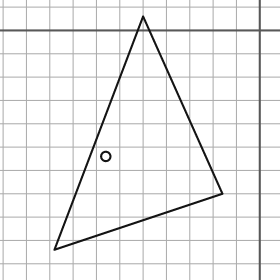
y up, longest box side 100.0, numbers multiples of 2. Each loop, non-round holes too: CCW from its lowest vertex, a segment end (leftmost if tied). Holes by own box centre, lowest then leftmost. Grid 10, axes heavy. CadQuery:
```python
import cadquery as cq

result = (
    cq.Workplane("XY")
    .moveTo(-88.0, -94.0)
    .lineTo(-16.0, -70.0)
    .lineTo(-50.0, 6.0)
    .close()
    .moveTo(-66.0, -54.0)
    .circle(2.0)
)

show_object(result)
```